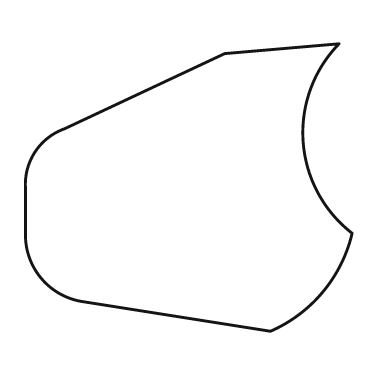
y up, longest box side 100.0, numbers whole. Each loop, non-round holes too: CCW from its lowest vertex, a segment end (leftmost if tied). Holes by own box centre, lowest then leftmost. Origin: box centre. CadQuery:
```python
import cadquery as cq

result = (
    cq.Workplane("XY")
    .moveTo(25.0, -44.0)
    .threePointArc((41.0, -32.0), (50.0, -14.0))
    .threePointArc((35.0, 14.0), (46.0, 44.0))
    .lineTo(11.0, 41.0)
    .lineTo(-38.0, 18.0)
    .threePointArc((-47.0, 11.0), (-50.0, 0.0))
    .lineTo(-50.0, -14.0)
    .threePointArc((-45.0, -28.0), (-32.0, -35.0))
    .close()
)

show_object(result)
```